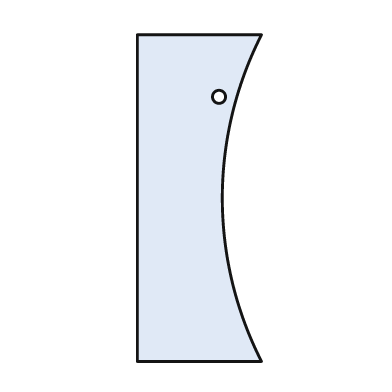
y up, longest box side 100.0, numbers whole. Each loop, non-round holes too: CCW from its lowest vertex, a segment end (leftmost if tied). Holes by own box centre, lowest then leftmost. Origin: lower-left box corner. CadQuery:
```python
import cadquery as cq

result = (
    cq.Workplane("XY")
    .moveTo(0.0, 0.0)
    .lineTo(38.0, 0.0)
    .threePointArc((26.0, 50.0), (38.0, 100.0))
    .lineTo(0.0, 100.0)
    .close()
    .moveTo(25.0, 81.0)
    .circle(2.0)
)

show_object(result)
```